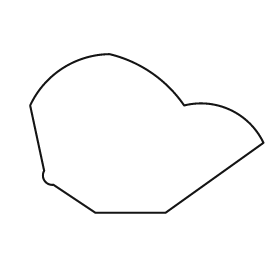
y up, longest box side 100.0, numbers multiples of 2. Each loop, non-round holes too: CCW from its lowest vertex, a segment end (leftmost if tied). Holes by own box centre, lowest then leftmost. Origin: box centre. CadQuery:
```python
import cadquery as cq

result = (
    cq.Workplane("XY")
    .moveTo(-22.0, -34.0)
    .lineTo(8.0, -34.0)
    .lineTo(50.0, -4.0)
    .threePointArc((36.0, 10.0), (16.0, 12.0))
    .threePointArc((2.0, 26.0), (-16.0, 34.0))
    .threePointArc((-36.0, 28.0), (-50.0, 12.0))
    .lineTo(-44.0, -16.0)
    .threePointArc((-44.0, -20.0), (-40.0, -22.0))
    .close()
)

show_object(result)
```